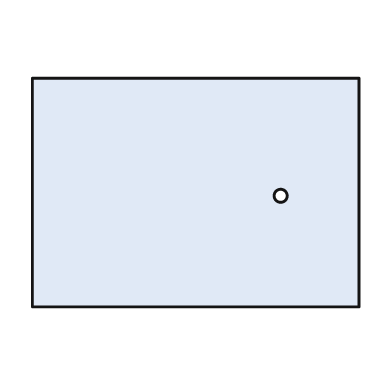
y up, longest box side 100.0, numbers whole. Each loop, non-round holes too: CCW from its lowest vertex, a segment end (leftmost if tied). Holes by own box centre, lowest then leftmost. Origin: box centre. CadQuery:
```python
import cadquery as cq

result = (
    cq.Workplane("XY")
    .moveTo(-50.0, -35.0)
    .lineTo(50.0, -35.0)
    .lineTo(50.0, 35.0)
    .lineTo(-50.0, 35.0)
    .close()
    .moveTo(26.0, -1.0)
    .circle(2.0)
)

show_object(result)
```